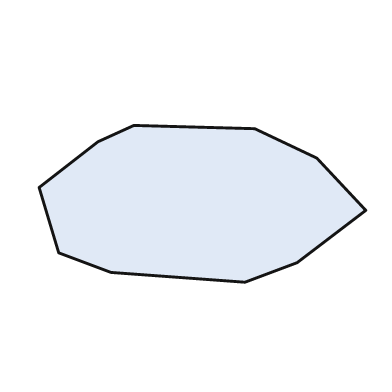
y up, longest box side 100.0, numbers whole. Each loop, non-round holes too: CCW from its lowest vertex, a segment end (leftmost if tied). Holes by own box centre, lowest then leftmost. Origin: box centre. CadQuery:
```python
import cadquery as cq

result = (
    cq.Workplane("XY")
    .moveTo(13.0, -24.0)
    .lineTo(29.0, -18.0)
    .lineTo(50.0, -2.0)
    .lineTo(35.0, 14.0)
    .lineTo(16.0, 23.0)
    .lineTo(-21.0, 24.0)
    .lineTo(-32.0, 19.0)
    .lineTo(-50.0, 5.0)
    .lineTo(-44.0, -15.0)
    .lineTo(-28.0, -21.0)
    .close()
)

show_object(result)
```